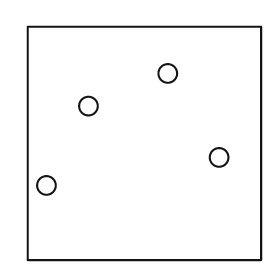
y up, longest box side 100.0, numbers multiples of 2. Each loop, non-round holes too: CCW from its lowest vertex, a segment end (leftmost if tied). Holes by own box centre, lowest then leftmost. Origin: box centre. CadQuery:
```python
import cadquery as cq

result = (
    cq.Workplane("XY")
    .moveTo(-50.0, -50.0)
    .lineTo(50.0, -50.0)
    .lineTo(50.0, 50.0)
    .lineTo(-50.0, 50.0)
    .close()
    .moveTo(-42.0, -18.0)
    .circle(4.0)
    .moveTo(32.0, -6.0)
    .circle(4.0)
    .moveTo(-24.0, 16.0)
    .circle(4.0)
    .moveTo(10.0, 30.0)
    .circle(4.0)
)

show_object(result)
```